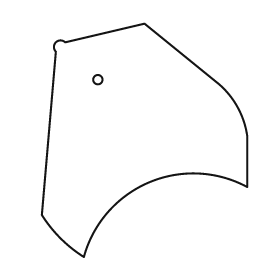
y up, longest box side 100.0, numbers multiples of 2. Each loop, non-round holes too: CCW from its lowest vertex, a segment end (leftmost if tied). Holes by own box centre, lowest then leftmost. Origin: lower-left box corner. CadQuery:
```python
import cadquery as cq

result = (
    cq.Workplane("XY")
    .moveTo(18.0, 0.0)
    .threePointArc((46.0, 32.0), (88.0, 30.0))
    .lineTo(88.0, 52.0)
    .threePointArc((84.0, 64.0), (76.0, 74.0))
    .lineTo(44.0, 100.0)
    .lineTo(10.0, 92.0)
    .threePointArc((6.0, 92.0), (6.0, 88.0))
    .lineTo(0.0, 18.0)
    .threePointArc((8.0, 8.0), (18.0, 0.0))
    .close()
    .moveTo(24.0, 76.0)
    .circle(2.0)
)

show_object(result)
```